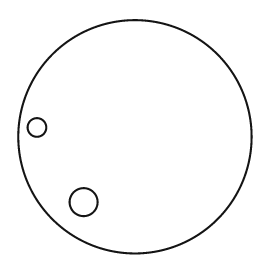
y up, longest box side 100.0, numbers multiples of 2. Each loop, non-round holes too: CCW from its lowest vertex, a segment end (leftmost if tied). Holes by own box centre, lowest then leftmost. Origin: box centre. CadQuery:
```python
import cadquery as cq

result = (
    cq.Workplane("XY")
    .moveTo(0.0, 0.0)
    .circle(50.0)
    .moveTo(-22.0, -28.0)
    .circle(6.0)
    .moveTo(-42.0, 4.0)
    .circle(4.0)
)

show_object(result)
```